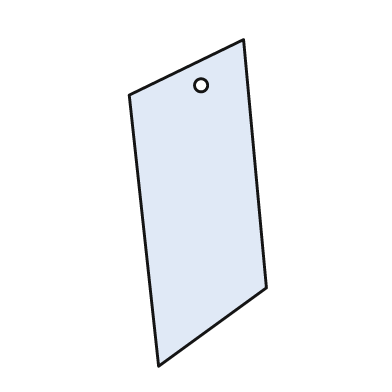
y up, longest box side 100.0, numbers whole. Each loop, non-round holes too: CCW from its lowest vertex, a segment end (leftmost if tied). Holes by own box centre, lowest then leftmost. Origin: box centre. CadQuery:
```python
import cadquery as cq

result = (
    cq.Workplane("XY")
    .moveTo(-12.0, -50.0)
    .lineTo(21.0, -26.0)
    .lineTo(14.0, 50.0)
    .lineTo(-21.0, 33.0)
    .close()
    .moveTo(1.0, 36.0)
    .circle(2.0)
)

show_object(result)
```